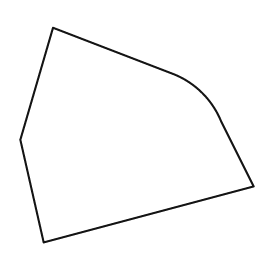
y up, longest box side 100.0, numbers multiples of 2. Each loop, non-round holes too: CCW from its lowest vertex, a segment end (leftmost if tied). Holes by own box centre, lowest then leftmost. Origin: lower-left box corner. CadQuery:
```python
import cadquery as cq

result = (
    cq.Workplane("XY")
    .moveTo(10.0, 0.0)
    .lineTo(100.0, 24.0)
    .lineTo(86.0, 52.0)
    .threePointArc((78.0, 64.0), (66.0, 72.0))
    .lineTo(14.0, 92.0)
    .lineTo(0.0, 44.0)
    .close()
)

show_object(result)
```